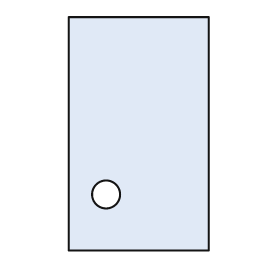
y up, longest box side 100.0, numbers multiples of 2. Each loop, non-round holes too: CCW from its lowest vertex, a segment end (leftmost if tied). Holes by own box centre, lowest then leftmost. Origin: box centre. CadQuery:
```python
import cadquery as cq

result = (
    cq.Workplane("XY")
    .moveTo(-30.0, -50.0)
    .lineTo(30.0, -50.0)
    .lineTo(30.0, 50.0)
    .lineTo(-30.0, 50.0)
    .close()
    .moveTo(-14.0, -26.0)
    .circle(6.0)
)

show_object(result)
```